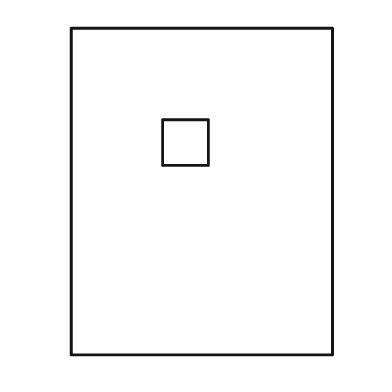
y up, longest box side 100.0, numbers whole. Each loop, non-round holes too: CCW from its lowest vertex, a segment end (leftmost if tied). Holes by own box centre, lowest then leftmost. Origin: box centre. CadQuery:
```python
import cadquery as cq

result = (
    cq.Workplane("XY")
    .moveTo(-40.0, -50.0)
    .lineTo(40.0, -50.0)
    .lineTo(40.0, 50.0)
    .lineTo(-40.0, 50.0)
    .close()
    .moveTo(-12.0, 8.0)
    .lineTo(2.0, 8.0)
    .lineTo(2.0, 22.0)
    .lineTo(-12.0, 22.0)
    .close()
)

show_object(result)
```